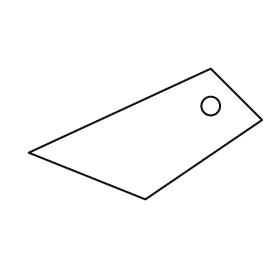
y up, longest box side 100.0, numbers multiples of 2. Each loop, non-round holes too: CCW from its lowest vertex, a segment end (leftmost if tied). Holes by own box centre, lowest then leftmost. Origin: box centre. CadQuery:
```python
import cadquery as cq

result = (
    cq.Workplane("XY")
    .moveTo(0.0, -28.0)
    .lineTo(50.0, 6.0)
    .lineTo(28.0, 28.0)
    .lineTo(-50.0, -8.0)
    .close()
    .moveTo(28.0, 12.0)
    .circle(4.0)
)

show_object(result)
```